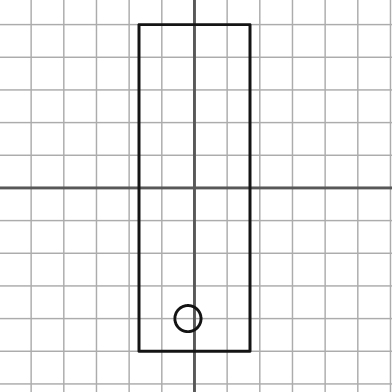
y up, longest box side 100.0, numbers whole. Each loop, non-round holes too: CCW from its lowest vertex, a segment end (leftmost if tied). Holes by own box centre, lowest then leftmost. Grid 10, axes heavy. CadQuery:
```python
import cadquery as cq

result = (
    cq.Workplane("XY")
    .moveTo(-17.0, -50.0)
    .lineTo(17.0, -50.0)
    .lineTo(17.0, 50.0)
    .lineTo(-17.0, 50.0)
    .close()
    .moveTo(-2.0, -40.0)
    .circle(4.0)
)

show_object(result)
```